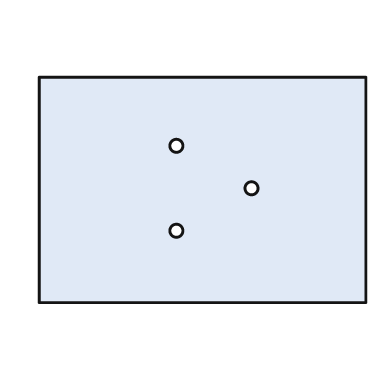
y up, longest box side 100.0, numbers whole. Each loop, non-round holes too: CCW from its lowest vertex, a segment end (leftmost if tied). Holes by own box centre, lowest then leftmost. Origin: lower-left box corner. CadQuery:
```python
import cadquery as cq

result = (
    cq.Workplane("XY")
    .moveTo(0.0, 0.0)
    .lineTo(100.0, 0.0)
    .lineTo(100.0, 69.0)
    .lineTo(0.0, 69.0)
    .close()
    .moveTo(42.0, 22.0)
    .circle(2.0)
    .moveTo(65.0, 35.0)
    .circle(2.0)
    .moveTo(42.0, 48.0)
    .circle(2.0)
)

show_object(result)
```